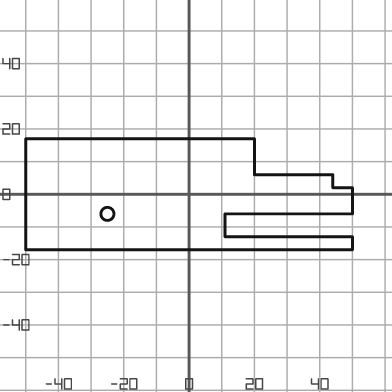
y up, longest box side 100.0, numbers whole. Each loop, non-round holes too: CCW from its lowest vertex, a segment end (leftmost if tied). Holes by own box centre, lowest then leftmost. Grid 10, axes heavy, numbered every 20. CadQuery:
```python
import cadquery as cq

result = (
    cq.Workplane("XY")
    .moveTo(-50.0, -17.0)
    .lineTo(50.0, -17.0)
    .lineTo(50.0, -13.0)
    .lineTo(11.0, -13.0)
    .lineTo(11.0, -6.0)
    .lineTo(50.0, -6.0)
    .lineTo(50.0, 2.0)
    .lineTo(44.0, 2.0)
    .lineTo(44.0, 6.0)
    .lineTo(20.0, 6.0)
    .lineTo(20.0, 17.0)
    .lineTo(-50.0, 17.0)
    .close()
    .moveTo(-25.0, -6.0)
    .circle(2.0)
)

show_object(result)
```